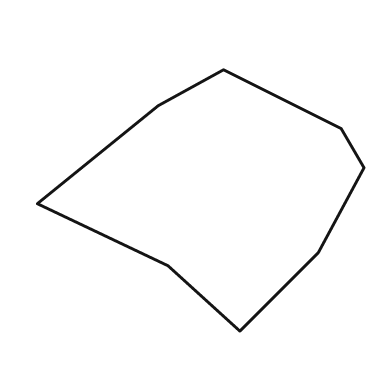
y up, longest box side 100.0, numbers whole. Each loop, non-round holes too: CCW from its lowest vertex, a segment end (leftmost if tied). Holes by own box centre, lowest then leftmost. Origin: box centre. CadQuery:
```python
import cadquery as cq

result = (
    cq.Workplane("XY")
    .moveTo(12.0, -40.0)
    .lineTo(36.0, -16.0)
    .lineTo(50.0, 10.0)
    .lineTo(43.0, 22.0)
    .lineTo(7.0, 40.0)
    .lineTo(-13.0, 29.0)
    .lineTo(-50.0, -1.0)
    .lineTo(-10.0, -20.0)
    .close()
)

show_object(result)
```